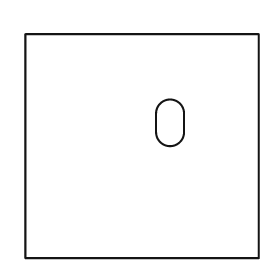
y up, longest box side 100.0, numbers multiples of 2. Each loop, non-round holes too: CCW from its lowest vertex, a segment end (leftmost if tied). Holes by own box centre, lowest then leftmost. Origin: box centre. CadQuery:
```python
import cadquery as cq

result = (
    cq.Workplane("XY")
    .moveTo(-50.0, -48.0)
    .lineTo(50.0, -48.0)
    .lineTo(50.0, 48.0)
    .lineTo(-50.0, 48.0)
    .close()
    .moveTo(6.0, 6.0)
    .threePointArc((12.0, 0.0), (18.0, 6.0))
    .lineTo(18.0, 14.0)
    .threePointArc((12.0, 20.0), (6.0, 14.0))
    .close()
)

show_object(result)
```